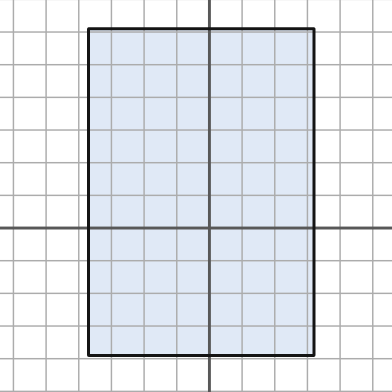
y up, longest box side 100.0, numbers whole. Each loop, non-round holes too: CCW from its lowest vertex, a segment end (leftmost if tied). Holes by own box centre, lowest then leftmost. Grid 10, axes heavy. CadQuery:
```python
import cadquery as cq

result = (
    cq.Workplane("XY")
    .moveTo(-37.0, -39.0)
    .lineTo(32.0, -39.0)
    .lineTo(32.0, 61.0)
    .lineTo(-37.0, 61.0)
    .close()
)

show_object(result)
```